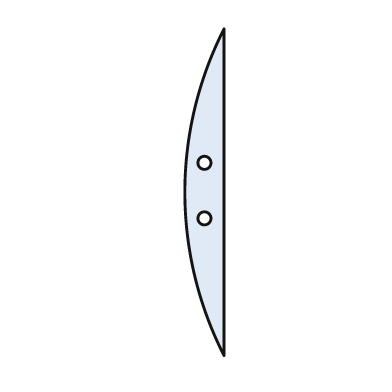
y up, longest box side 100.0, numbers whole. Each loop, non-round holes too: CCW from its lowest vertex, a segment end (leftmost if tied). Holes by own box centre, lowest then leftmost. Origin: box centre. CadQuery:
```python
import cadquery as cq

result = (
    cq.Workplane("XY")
    .moveTo(6.0, -50.0)
    .lineTo(6.0, 50.0)
    .threePointArc((-6.0, 0.0), (6.0, -50.0))
    .close()
    .moveTo(0.0, -8.0)
    .circle(2.0)
    .moveTo(0.0, 9.0)
    .circle(2.0)
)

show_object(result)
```